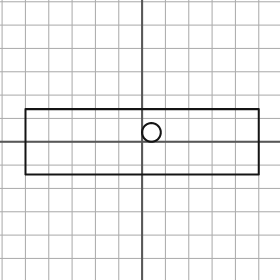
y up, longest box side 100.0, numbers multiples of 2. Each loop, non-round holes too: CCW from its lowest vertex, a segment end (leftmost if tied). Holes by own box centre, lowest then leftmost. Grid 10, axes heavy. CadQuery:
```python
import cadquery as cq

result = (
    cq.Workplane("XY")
    .moveTo(-50.0, -14.0)
    .lineTo(50.0, -14.0)
    .lineTo(50.0, 14.0)
    .lineTo(-50.0, 14.0)
    .close()
    .moveTo(4.0, 4.0)
    .circle(4.0)
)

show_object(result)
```